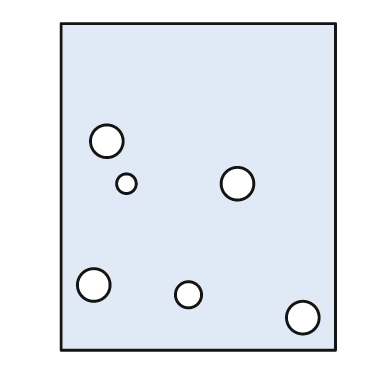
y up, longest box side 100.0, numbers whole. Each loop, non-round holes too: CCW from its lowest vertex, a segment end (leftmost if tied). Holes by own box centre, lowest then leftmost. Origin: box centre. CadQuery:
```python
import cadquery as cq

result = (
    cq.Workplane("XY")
    .moveTo(-42.0, -50.0)
    .lineTo(42.0, -50.0)
    .lineTo(42.0, 50.0)
    .lineTo(-42.0, 50.0)
    .close()
    .moveTo(32.0, -40.0)
    .circle(5.0)
    .moveTo(-3.0, -33.0)
    .circle(4.0)
    .moveTo(-32.0, -30.0)
    .circle(5.0)
    .moveTo(-22.0, 1.0)
    .circle(3.0)
    .moveTo(12.0, 1.0)
    .circle(5.0)
    .moveTo(-28.0, 14.0)
    .circle(5.0)
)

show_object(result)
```